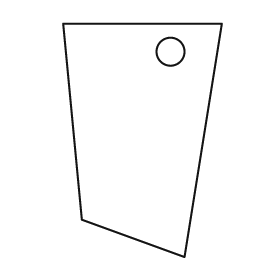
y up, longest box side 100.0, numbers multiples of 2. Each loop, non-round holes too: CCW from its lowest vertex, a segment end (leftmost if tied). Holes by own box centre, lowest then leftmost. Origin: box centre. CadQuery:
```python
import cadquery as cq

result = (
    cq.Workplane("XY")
    .moveTo(18.0, -50.0)
    .lineTo(34.0, 50.0)
    .lineTo(-34.0, 50.0)
    .lineTo(-26.0, -34.0)
    .close()
    .moveTo(12.0, 38.0)
    .circle(6.0)
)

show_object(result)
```